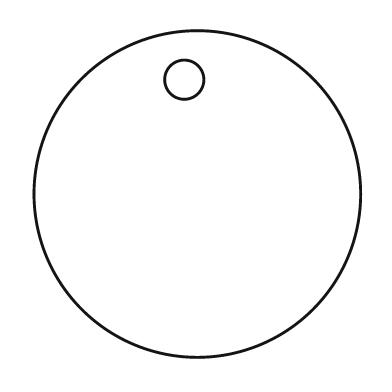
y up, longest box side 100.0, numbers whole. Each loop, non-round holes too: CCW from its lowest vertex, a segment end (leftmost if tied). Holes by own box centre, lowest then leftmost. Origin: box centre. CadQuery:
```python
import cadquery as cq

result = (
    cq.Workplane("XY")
    .moveTo(0.0, 0.0)
    .circle(50.0)
    .moveTo(-4.0, 35.0)
    .circle(6.0)
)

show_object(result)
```